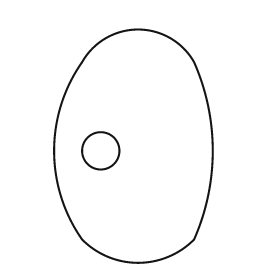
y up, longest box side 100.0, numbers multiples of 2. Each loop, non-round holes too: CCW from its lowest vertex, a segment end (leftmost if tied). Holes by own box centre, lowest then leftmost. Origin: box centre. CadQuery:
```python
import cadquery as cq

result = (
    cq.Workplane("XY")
    .moveTo(-22.0, -40.0)
    .threePointArc((2.0, -50.0), (26.0, -40.0))
    .threePointArc((34.0, -2.0), (26.0, 36.0))
    .threePointArc((2.0, 50.0), (-22.0, 36.0))
    .threePointArc((-34.0, -2.0), (-22.0, -40.0))
    .close()
    .moveTo(-14.0, -2.0)
    .circle(8.0)
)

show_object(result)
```